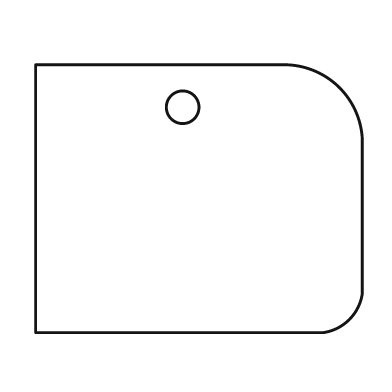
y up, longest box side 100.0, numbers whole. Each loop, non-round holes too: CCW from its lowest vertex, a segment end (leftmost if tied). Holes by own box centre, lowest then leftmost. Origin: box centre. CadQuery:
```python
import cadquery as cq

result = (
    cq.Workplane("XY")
    .moveTo(-50.0, -41.0)
    .lineTo(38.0, -41.0)
    .threePointArc((46.0, -37.0), (50.0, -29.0))
    .lineTo(50.0, 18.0)
    .threePointArc((43.0, 34.0), (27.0, 41.0))
    .lineTo(-50.0, 41.0)
    .close()
    .moveTo(-5.0, 28.0)
    .circle(5.0)
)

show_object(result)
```